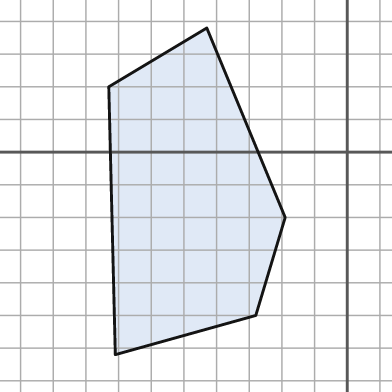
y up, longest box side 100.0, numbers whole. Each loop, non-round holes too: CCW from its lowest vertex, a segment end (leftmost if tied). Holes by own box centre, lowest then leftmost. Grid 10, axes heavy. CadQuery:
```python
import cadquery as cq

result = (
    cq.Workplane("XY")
    .moveTo(-71.0, -62.0)
    .lineTo(-28.0, -50.0)
    .lineTo(-19.0, -20.0)
    .lineTo(-43.0, 38.0)
    .lineTo(-73.0, 20.0)
    .close()
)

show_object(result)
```